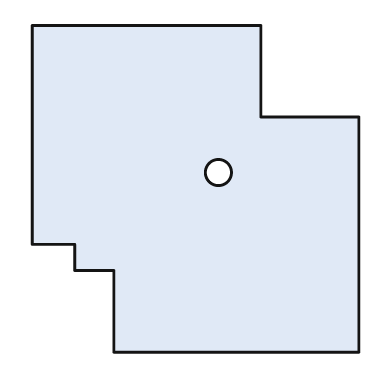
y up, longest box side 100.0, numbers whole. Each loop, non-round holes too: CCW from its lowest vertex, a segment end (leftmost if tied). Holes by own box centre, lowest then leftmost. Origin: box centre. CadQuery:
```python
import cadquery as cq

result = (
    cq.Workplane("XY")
    .moveTo(-25.0, -50.0)
    .lineTo(50.0, -50.0)
    .lineTo(50.0, 22.0)
    .lineTo(20.0, 22.0)
    .lineTo(20.0, 50.0)
    .lineTo(-50.0, 50.0)
    .lineTo(-50.0, -17.0)
    .lineTo(-37.0, -17.0)
    .lineTo(-37.0, -25.0)
    .lineTo(-25.0, -25.0)
    .close()
    .moveTo(7.0, 5.0)
    .circle(4.0)
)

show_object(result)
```